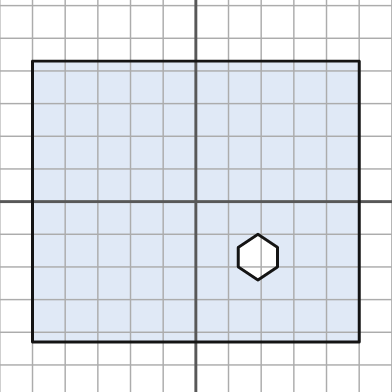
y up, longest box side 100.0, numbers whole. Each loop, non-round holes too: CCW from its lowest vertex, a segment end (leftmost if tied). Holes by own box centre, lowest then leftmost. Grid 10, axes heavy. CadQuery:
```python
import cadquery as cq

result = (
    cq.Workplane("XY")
    .moveTo(-50.0, -43.0)
    .lineTo(50.0, -43.0)
    .lineTo(50.0, 43.0)
    .lineTo(-50.0, 43.0)
    .close()
    .moveTo(19.0, -24.0)
    .lineTo(25.0, -20.0)
    .lineTo(25.0, -14.0)
    .lineTo(19.0, -10.0)
    .lineTo(13.0, -14.0)
    .lineTo(13.0, -20.0)
    .close()
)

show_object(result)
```